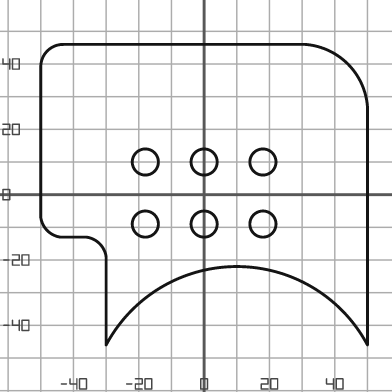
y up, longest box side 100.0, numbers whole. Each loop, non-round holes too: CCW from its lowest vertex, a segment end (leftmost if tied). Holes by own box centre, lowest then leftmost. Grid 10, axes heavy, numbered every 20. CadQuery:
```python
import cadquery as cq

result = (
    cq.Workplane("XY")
    .moveTo(-30.0, -46.0)
    .threePointArc((10.0, -22.0), (50.0, -46.0))
    .lineTo(50.0, 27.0)
    .threePointArc((44.0, 40.0), (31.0, 46.0))
    .lineTo(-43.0, 46.0)
    .threePointArc((-48.0, 44.0), (-50.0, 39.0))
    .lineTo(-50.0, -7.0)
    .threePointArc((-48.0, -11.0), (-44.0, -13.0))
    .lineTo(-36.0, -13.0)
    .threePointArc((-32.0, -15.0), (-30.0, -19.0))
    .close()
    .moveTo(-18.0, -9.0)
    .circle(4.0)
    .moveTo(0.0, -9.0)
    .circle(4.0)
    .moveTo(18.0, -9.0)
    .circle(4.0)
    .moveTo(-18.0, 10.0)
    .circle(4.0)
    .moveTo(0.0, 10.0)
    .circle(4.0)
    .moveTo(18.0, 10.0)
    .circle(4.0)
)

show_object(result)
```